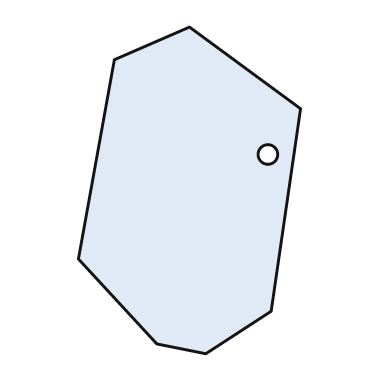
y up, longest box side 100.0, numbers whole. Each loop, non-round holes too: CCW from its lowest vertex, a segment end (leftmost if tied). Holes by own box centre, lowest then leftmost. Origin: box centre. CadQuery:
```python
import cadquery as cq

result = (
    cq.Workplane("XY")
    .moveTo(5.0, -50.0)
    .lineTo(25.0, -37.0)
    .lineTo(34.0, 25.0)
    .lineTo(0.0, 50.0)
    .lineTo(-23.0, 40.0)
    .lineTo(-34.0, -21.0)
    .lineTo(-10.0, -47.0)
    .close()
    .moveTo(24.0, 11.0)
    .circle(3.0)
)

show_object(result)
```